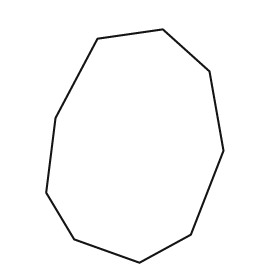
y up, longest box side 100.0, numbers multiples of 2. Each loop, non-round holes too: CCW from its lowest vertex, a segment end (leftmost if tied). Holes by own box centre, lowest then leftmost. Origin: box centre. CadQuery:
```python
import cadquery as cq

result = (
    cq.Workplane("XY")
    .moveTo(2.0, -50.0)
    .lineTo(24.0, -38.0)
    .lineTo(38.0, -2.0)
    .lineTo(32.0, 32.0)
    .lineTo(12.0, 50.0)
    .lineTo(-16.0, 46.0)
    .lineTo(-34.0, 12.0)
    .lineTo(-38.0, -20.0)
    .lineTo(-26.0, -40.0)
    .close()
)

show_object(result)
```